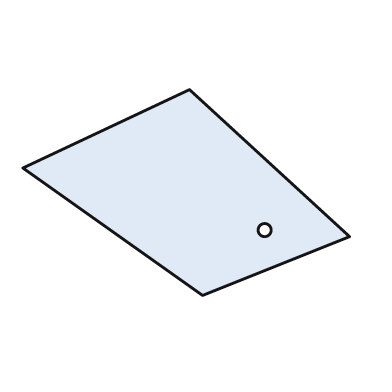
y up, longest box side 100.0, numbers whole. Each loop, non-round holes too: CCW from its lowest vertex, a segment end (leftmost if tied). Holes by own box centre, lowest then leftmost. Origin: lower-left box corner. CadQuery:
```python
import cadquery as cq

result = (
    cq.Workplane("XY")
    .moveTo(55.0, 0.0)
    .lineTo(100.0, 18.0)
    .lineTo(51.0, 63.0)
    .lineTo(0.0, 39.0)
    .close()
    .moveTo(74.0, 20.0)
    .circle(2.0)
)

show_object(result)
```